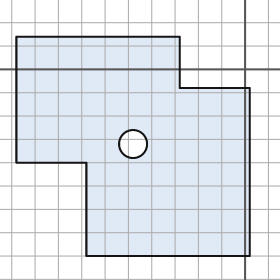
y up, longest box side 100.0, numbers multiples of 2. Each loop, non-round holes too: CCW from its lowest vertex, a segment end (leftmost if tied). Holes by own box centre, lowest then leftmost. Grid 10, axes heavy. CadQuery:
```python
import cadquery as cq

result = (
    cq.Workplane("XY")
    .moveTo(-68.0, -80.0)
    .lineTo(2.0, -80.0)
    .lineTo(2.0, -8.0)
    .lineTo(-28.0, -8.0)
    .lineTo(-28.0, 14.0)
    .lineTo(-98.0, 14.0)
    .lineTo(-98.0, -40.0)
    .lineTo(-68.0, -40.0)
    .close()
    .moveTo(-48.0, -32.0)
    .circle(6.0)
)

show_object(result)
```